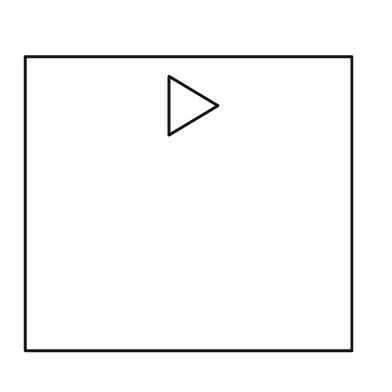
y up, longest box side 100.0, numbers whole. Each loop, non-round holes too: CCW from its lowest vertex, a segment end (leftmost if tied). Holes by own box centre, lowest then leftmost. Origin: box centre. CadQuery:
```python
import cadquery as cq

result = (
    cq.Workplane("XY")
    .moveTo(-50.0, -45.0)
    .lineTo(50.0, -45.0)
    .lineTo(50.0, 45.0)
    .lineTo(-50.0, 45.0)
    .close()
    .moveTo(-6.0, 21.0)
    .lineTo(9.0, 30.0)
    .lineTo(-6.0, 39.0)
    .close()
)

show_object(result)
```